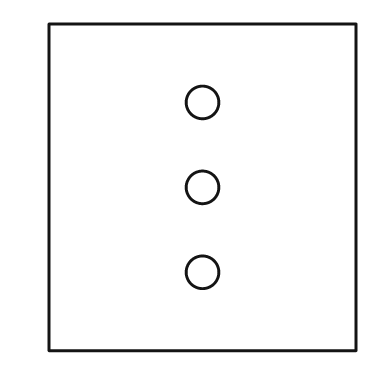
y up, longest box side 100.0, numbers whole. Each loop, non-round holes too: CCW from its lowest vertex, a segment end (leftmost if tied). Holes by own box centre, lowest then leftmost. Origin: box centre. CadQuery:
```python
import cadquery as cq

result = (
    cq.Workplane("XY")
    .moveTo(-47.0, -50.0)
    .lineTo(47.0, -50.0)
    .lineTo(47.0, 50.0)
    .lineTo(-47.0, 50.0)
    .close()
    .moveTo(0.0, -26.0)
    .circle(5.0)
    .moveTo(0.0, 0.0)
    .circle(5.0)
    .moveTo(0.0, 26.0)
    .circle(5.0)
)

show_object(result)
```